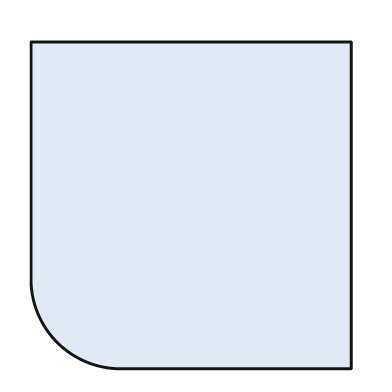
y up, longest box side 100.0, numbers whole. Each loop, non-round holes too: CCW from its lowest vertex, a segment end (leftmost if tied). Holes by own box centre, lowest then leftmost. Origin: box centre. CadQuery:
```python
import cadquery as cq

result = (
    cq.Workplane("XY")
    .moveTo(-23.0, -50.0)
    .lineTo(49.0, -50.0)
    .lineTo(49.0, 50.0)
    .lineTo(-49.0, 50.0)
    .lineTo(-49.0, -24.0)
    .threePointArc((-41.0, -42.0), (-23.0, -50.0))
    .close()
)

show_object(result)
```